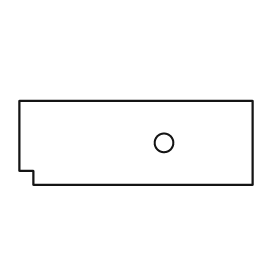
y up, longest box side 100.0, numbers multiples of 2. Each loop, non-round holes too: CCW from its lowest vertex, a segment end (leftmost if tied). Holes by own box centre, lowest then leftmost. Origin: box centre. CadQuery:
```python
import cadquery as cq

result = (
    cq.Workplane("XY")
    .moveTo(-44.0, -18.0)
    .lineTo(50.0, -18.0)
    .lineTo(50.0, 18.0)
    .lineTo(-50.0, 18.0)
    .lineTo(-50.0, -12.0)
    .lineTo(-44.0, -12.0)
    .close()
    .moveTo(12.0, 0.0)
    .circle(4.0)
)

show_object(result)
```